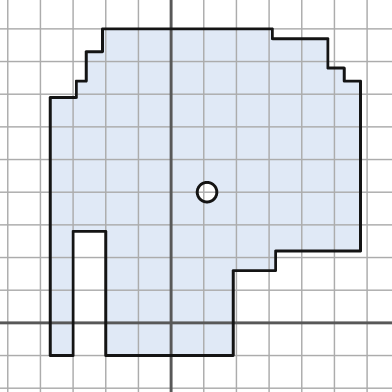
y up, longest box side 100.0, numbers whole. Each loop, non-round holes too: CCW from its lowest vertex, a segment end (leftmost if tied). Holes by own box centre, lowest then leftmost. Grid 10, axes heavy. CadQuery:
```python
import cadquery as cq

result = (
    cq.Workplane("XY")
    .moveTo(-37.0, -10.0)
    .lineTo(-30.0, -10.0)
    .lineTo(-30.0, 28.0)
    .lineTo(-20.0, 28.0)
    .lineTo(-20.0, -10.0)
    .lineTo(19.0, -10.0)
    .lineTo(19.0, 16.0)
    .lineTo(32.0, 16.0)
    .lineTo(32.0, 22.0)
    .lineTo(58.0, 22.0)
    .lineTo(58.0, 74.0)
    .lineTo(53.0, 74.0)
    .lineTo(53.0, 78.0)
    .lineTo(48.0, 78.0)
    .lineTo(48.0, 87.0)
    .lineTo(31.0, 87.0)
    .lineTo(31.0, 90.0)
    .lineTo(-21.0, 90.0)
    .lineTo(-21.0, 83.0)
    .lineTo(-26.0, 83.0)
    .lineTo(-26.0, 74.0)
    .lineTo(-29.0, 74.0)
    .lineTo(-29.0, 69.0)
    .lineTo(-37.0, 69.0)
    .close()
    .moveTo(11.0, 40.0)
    .circle(3.0)
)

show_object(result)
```